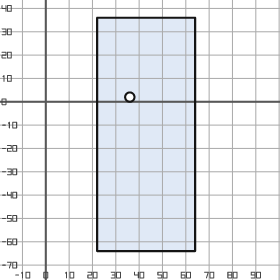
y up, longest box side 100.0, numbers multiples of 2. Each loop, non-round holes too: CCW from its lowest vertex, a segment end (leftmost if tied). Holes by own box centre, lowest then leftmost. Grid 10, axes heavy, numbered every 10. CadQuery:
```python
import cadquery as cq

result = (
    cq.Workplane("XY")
    .moveTo(22.0, -64.0)
    .lineTo(64.0, -64.0)
    .lineTo(64.0, 36.0)
    .lineTo(22.0, 36.0)
    .close()
    .moveTo(36.0, 2.0)
    .circle(2.0)
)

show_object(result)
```